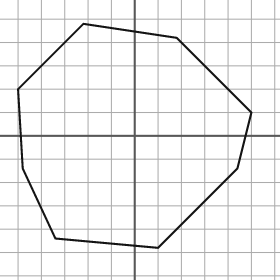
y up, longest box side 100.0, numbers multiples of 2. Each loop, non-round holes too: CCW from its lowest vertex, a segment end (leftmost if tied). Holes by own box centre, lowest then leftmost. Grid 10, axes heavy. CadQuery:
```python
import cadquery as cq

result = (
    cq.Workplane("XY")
    .moveTo(10.0, -48.0)
    .lineTo(44.0, -14.0)
    .lineTo(50.0, 10.0)
    .lineTo(18.0, 42.0)
    .lineTo(-22.0, 48.0)
    .lineTo(-50.0, 20.0)
    .lineTo(-48.0, -14.0)
    .lineTo(-34.0, -44.0)
    .close()
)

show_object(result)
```